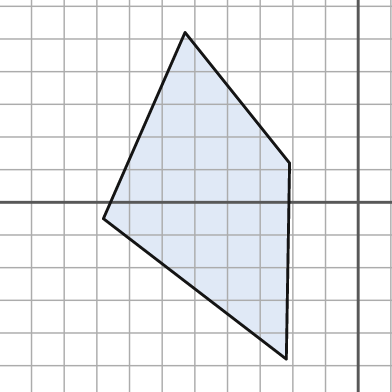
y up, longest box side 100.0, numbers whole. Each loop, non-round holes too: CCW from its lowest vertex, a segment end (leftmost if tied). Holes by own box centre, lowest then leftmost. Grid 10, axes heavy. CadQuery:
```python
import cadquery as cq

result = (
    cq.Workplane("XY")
    .moveTo(-22.0, -48.0)
    .lineTo(-21.0, 12.0)
    .lineTo(-53.0, 52.0)
    .lineTo(-78.0, -5.0)
    .close()
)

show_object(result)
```